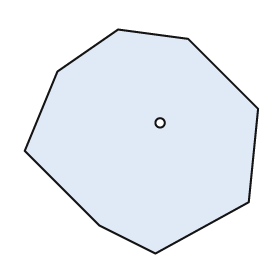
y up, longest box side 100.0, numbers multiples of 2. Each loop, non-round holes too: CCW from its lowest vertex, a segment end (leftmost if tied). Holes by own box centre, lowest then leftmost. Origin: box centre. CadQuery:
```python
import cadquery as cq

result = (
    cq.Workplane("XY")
    .moveTo(6.0, -48.0)
    .lineTo(46.0, -26.0)
    .lineTo(50.0, 14.0)
    .lineTo(20.0, 44.0)
    .lineTo(-10.0, 48.0)
    .lineTo(-36.0, 30.0)
    .lineTo(-50.0, -4.0)
    .lineTo(-18.0, -36.0)
    .close()
    .moveTo(8.0, 8.0)
    .circle(2.0)
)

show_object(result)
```